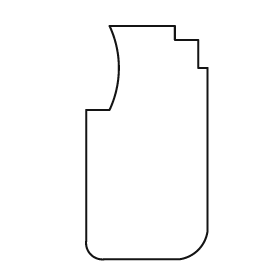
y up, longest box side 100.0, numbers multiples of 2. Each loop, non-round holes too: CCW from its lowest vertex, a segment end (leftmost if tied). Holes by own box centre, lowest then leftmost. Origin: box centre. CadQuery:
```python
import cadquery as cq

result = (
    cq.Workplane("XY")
    .moveTo(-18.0, -50.0)
    .lineTo(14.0, -50.0)
    .threePointArc((22.0, -46.0), (26.0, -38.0))
    .lineTo(26.0, 32.0)
    .lineTo(22.0, 32.0)
    .lineTo(22.0, 44.0)
    .lineTo(12.0, 44.0)
    .lineTo(12.0, 50.0)
    .lineTo(-16.0, 50.0)
    .threePointArc((-12.0, 32.0), (-16.0, 14.0))
    .lineTo(-26.0, 14.0)
    .lineTo(-26.0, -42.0)
    .threePointArc((-24.0, -48.0), (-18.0, -50.0))
    .close()
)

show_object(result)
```